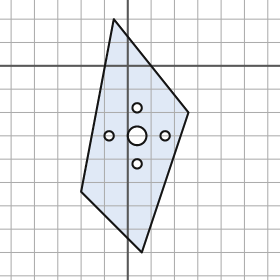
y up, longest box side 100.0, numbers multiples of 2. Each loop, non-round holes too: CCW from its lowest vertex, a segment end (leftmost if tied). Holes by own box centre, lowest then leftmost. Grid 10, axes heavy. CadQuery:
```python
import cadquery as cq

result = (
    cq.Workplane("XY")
    .moveTo(6.0, -80.0)
    .lineTo(26.0, -20.0)
    .lineTo(-6.0, 20.0)
    .lineTo(-20.0, -54.0)
    .close()
    .moveTo(4.0, -42.0)
    .circle(2.0)
    .moveTo(-8.0, -30.0)
    .circle(2.0)
    .moveTo(4.0, -30.0)
    .circle(4.0)
    .moveTo(16.0, -30.0)
    .circle(2.0)
    .moveTo(4.0, -18.0)
    .circle(2.0)
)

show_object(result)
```